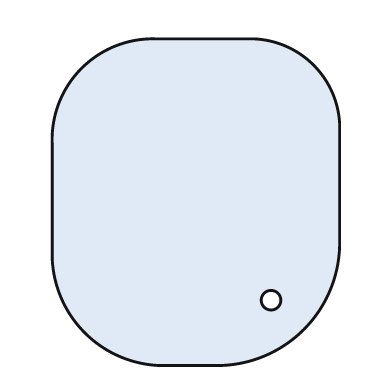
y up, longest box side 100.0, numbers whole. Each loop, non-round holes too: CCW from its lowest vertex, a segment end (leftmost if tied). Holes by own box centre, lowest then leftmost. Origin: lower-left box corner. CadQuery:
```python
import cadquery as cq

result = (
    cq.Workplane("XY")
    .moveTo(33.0, 0.0)
    .lineTo(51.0, 0.0)
    .threePointArc((77.0, 11.0), (88.0, 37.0))
    .lineTo(88.0, 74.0)
    .threePointArc((80.0, 92.0), (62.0, 100.0))
    .lineTo(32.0, 100.0)
    .threePointArc((9.0, 91.0), (0.0, 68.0))
    .lineTo(0.0, 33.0)
    .threePointArc((10.0, 10.0), (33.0, 0.0))
    .close()
    .moveTo(67.0, 20.0)
    .circle(3.0)
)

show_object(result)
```